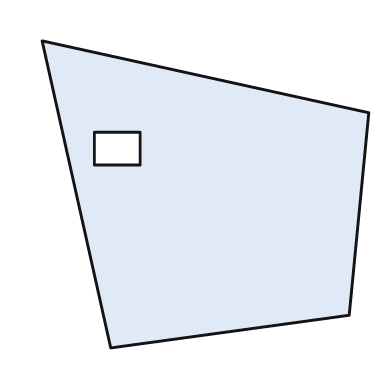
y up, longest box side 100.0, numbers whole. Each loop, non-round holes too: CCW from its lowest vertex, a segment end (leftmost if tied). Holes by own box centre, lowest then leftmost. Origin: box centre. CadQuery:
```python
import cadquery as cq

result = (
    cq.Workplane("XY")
    .moveTo(-29.0, -47.0)
    .lineTo(44.0, -37.0)
    .lineTo(50.0, 25.0)
    .lineTo(-50.0, 47.0)
    .close()
    .moveTo(-34.0, 9.0)
    .lineTo(-20.0, 9.0)
    .lineTo(-20.0, 19.0)
    .lineTo(-34.0, 19.0)
    .close()
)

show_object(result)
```